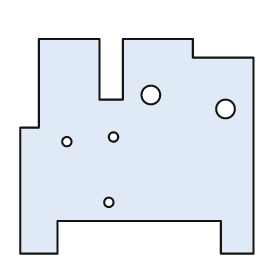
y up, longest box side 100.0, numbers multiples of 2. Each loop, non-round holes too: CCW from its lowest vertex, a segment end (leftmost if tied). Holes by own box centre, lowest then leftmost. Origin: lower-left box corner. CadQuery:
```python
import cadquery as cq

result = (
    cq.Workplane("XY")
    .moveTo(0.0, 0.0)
    .lineTo(16.0, 0.0)
    .lineTo(16.0, 14.0)
    .lineTo(86.0, 14.0)
    .lineTo(86.0, 0.0)
    .lineTo(100.0, 0.0)
    .lineTo(100.0, 84.0)
    .lineTo(74.0, 84.0)
    .lineTo(74.0, 92.0)
    .lineTo(44.0, 92.0)
    .lineTo(44.0, 66.0)
    .lineTo(34.0, 66.0)
    .lineTo(34.0, 92.0)
    .lineTo(8.0, 92.0)
    .lineTo(8.0, 54.0)
    .lineTo(0.0, 54.0)
    .close()
    .moveTo(38.0, 22.0)
    .circle(2.0)
    .moveTo(20.0, 48.0)
    .circle(2.0)
    .moveTo(40.0, 50.0)
    .circle(2.0)
    .moveTo(88.0, 62.0)
    .circle(4.0)
    .moveTo(56.0, 68.0)
    .circle(4.0)
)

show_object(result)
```